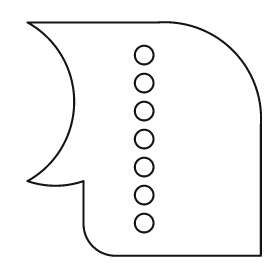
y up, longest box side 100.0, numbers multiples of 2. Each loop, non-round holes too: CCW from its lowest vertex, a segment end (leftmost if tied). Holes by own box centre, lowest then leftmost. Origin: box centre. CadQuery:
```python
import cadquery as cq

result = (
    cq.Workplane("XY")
    .moveTo(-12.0, -50.0)
    .lineTo(50.0, -50.0)
    .lineTo(50.0, 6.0)
    .threePointArc((38.0, 38.0), (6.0, 50.0))
    .lineTo(-50.0, 50.0)
    .threePointArc((-30.0, 16.0), (-50.0, -18.0))
    .threePointArc((-38.0, -20.0), (-26.0, -18.0))
    .lineTo(-26.0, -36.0)
    .threePointArc((-22.0, -46.0), (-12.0, -50.0))
    .close()
    .moveTo(0.0, -36.0)
    .circle(4.0)
    .moveTo(0.0, -24.0)
    .circle(4.0)
    .moveTo(0.0, -12.0)
    .circle(4.0)
    .moveTo(0.0, 0.0)
    .circle(4.0)
    .moveTo(0.0, 12.0)
    .circle(4.0)
    .moveTo(0.0, 24.0)
    .circle(4.0)
    .moveTo(0.0, 36.0)
    .circle(4.0)
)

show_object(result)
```